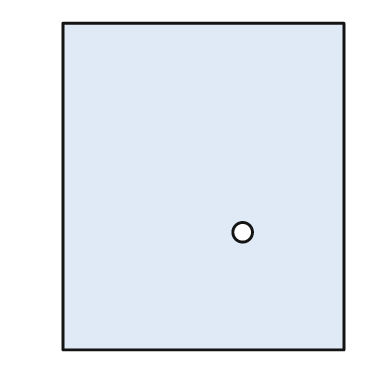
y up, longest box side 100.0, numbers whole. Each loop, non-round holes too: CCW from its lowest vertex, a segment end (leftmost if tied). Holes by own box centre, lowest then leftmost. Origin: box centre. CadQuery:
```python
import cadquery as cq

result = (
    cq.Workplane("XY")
    .moveTo(-43.0, -50.0)
    .lineTo(43.0, -50.0)
    .lineTo(43.0, 50.0)
    .lineTo(-43.0, 50.0)
    .close()
    .moveTo(12.0, -14.0)
    .circle(3.0)
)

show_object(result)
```